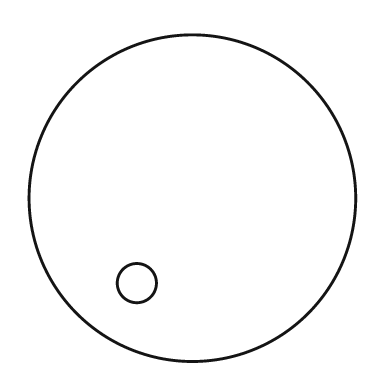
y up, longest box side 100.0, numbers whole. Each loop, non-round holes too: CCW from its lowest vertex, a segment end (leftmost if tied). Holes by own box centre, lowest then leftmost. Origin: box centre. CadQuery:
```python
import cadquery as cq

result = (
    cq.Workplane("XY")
    .moveTo(0.0, 0.0)
    .circle(50.0)
    .moveTo(-17.0, -26.0)
    .circle(6.0)
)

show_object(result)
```